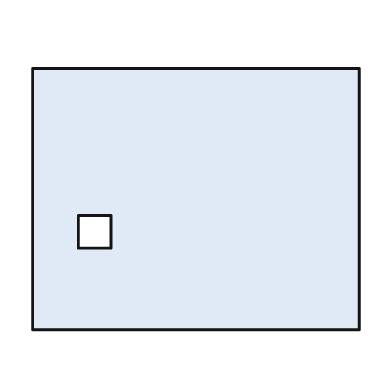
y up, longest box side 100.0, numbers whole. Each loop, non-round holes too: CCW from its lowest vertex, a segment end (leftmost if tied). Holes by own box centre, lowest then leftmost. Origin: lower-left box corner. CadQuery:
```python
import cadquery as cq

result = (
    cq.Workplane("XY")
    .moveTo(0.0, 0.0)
    .lineTo(100.0, 0.0)
    .lineTo(100.0, 80.0)
    .lineTo(0.0, 80.0)
    .close()
    .moveTo(14.0, 25.0)
    .lineTo(24.0, 25.0)
    .lineTo(24.0, 35.0)
    .lineTo(14.0, 35.0)
    .close()
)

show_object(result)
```